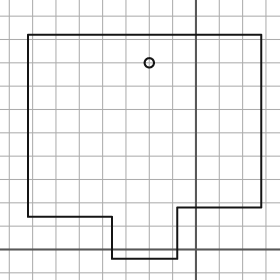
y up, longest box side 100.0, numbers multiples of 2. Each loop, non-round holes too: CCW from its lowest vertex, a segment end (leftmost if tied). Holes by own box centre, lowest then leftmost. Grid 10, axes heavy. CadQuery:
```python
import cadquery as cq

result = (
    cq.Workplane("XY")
    .moveTo(-36.0, -4.0)
    .lineTo(-8.0, -4.0)
    .lineTo(-8.0, 18.0)
    .lineTo(28.0, 18.0)
    .lineTo(28.0, 92.0)
    .lineTo(-72.0, 92.0)
    .lineTo(-72.0, 14.0)
    .lineTo(-36.0, 14.0)
    .close()
    .moveTo(-20.0, 80.0)
    .circle(2.0)
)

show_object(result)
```